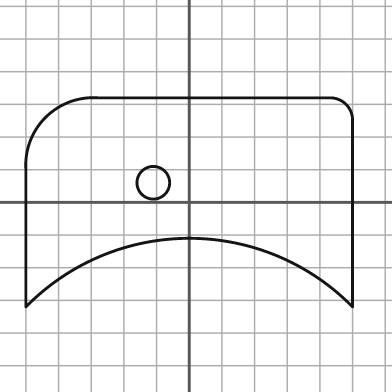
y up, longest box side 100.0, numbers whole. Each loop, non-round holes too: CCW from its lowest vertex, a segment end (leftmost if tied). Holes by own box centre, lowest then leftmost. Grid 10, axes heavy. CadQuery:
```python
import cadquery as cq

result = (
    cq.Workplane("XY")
    .moveTo(-50.0, -32.0)
    .threePointArc((0.0, -11.0), (50.0, -32.0))
    .lineTo(50.0, 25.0)
    .threePointArc((48.0, 30.0), (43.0, 32.0))
    .lineTo(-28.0, 32.0)
    .threePointArc((-44.0, 26.0), (-50.0, 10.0))
    .close()
    .moveTo(-11.0, 6.0)
    .circle(5.0)
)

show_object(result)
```